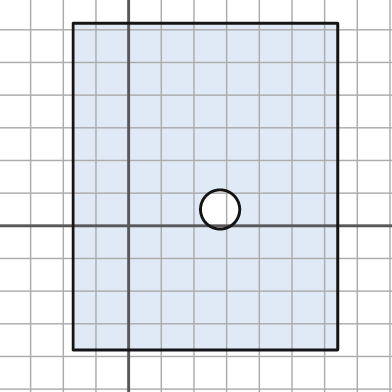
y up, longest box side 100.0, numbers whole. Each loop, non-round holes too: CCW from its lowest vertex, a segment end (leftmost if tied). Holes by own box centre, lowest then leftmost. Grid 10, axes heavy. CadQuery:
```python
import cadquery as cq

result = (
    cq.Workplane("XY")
    .moveTo(-17.0, -38.0)
    .lineTo(64.0, -38.0)
    .lineTo(64.0, 62.0)
    .lineTo(-17.0, 62.0)
    .close()
    .moveTo(28.0, 5.0)
    .circle(6.0)
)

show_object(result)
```